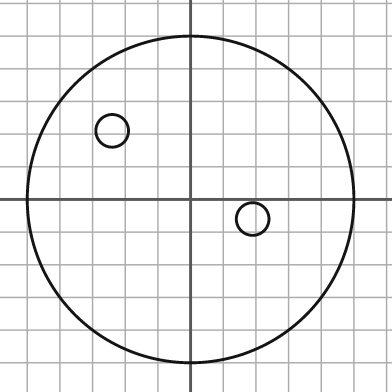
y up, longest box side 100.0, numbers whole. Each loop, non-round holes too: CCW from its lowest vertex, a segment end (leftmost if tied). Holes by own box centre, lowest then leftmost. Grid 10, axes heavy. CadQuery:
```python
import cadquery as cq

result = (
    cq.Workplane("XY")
    .moveTo(0.0, 0.0)
    .circle(50.0)
    .moveTo(19.0, -6.0)
    .circle(5.0)
    .moveTo(-24.0, 21.0)
    .circle(5.0)
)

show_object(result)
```